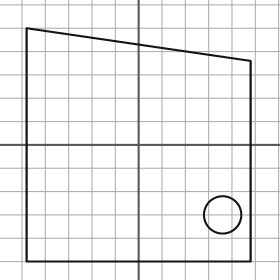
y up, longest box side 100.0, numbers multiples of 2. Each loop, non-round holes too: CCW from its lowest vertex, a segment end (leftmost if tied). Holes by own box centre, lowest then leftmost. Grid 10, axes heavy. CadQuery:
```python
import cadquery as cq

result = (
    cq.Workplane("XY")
    .moveTo(-48.0, -50.0)
    .lineTo(48.0, -50.0)
    .lineTo(48.0, 36.0)
    .lineTo(-48.0, 50.0)
    .close()
    .moveTo(36.0, -30.0)
    .circle(8.0)
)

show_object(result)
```